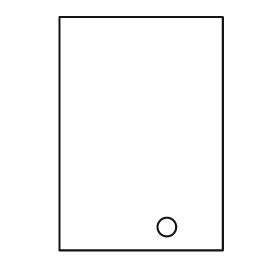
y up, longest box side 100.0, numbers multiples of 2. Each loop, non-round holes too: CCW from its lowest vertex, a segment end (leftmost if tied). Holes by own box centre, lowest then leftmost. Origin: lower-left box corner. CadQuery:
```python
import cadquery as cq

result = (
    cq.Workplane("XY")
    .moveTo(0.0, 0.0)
    .lineTo(70.0, 0.0)
    .lineTo(70.0, 100.0)
    .lineTo(0.0, 100.0)
    .close()
    .moveTo(46.0, 10.0)
    .circle(4.0)
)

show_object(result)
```